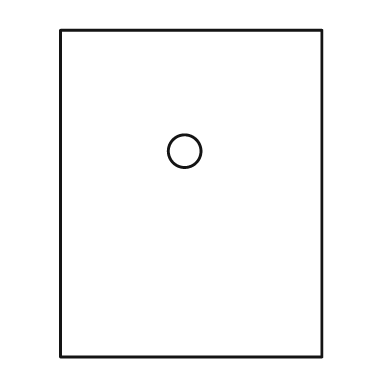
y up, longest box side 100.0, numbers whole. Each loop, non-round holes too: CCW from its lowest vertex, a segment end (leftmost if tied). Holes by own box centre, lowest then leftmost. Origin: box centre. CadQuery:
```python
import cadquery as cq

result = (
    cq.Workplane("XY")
    .moveTo(-40.0, -50.0)
    .lineTo(40.0, -50.0)
    .lineTo(40.0, 50.0)
    .lineTo(-40.0, 50.0)
    .close()
    .moveTo(-2.0, 13.0)
    .circle(5.0)
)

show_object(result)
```